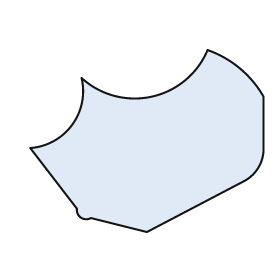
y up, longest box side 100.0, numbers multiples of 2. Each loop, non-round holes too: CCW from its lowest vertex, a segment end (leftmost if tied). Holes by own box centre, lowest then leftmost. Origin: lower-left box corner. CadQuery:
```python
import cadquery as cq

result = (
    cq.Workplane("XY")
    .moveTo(50.0, 0.0)
    .lineTo(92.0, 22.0)
    .threePointArc((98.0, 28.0), (100.0, 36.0))
    .lineTo(100.0, 58.0)
    .threePointArc((90.0, 70.0), (76.0, 78.0))
    .threePointArc((52.0, 58.0), (22.0, 66.0))
    .threePointArc((18.0, 46.0), (0.0, 36.0))
    .lineTo(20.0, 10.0)
    .threePointArc((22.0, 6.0), (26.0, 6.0))
    .close()
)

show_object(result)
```